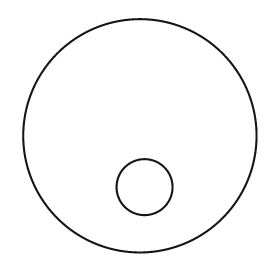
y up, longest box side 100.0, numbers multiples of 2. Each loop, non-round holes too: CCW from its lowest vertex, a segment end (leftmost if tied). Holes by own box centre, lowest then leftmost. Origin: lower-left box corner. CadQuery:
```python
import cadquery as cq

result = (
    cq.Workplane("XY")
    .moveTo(50.0, 50.0)
    .circle(50.0)
    .moveTo(52.0, 28.0)
    .circle(12.0)
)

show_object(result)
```